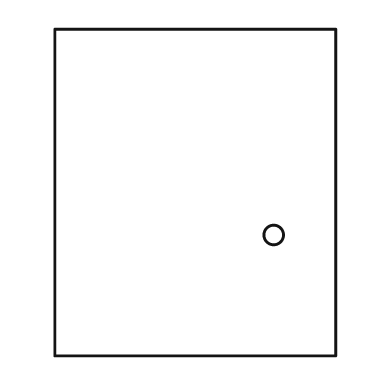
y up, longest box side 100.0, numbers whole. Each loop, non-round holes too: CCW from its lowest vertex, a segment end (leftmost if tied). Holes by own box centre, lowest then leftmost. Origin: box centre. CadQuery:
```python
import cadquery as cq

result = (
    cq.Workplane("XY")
    .moveTo(-43.0, -50.0)
    .lineTo(43.0, -50.0)
    .lineTo(43.0, 50.0)
    .lineTo(-43.0, 50.0)
    .close()
    .moveTo(24.0, -13.0)
    .circle(3.0)
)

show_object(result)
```